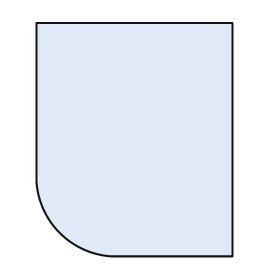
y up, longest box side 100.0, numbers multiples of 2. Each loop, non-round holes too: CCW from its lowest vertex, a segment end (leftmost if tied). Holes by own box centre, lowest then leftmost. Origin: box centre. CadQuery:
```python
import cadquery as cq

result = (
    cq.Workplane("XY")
    .moveTo(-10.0, -50.0)
    .lineTo(42.0, -50.0)
    .lineTo(42.0, 50.0)
    .lineTo(-42.0, 50.0)
    .lineTo(-42.0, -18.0)
    .threePointArc((-32.0, -40.0), (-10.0, -50.0))
    .close()
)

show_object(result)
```